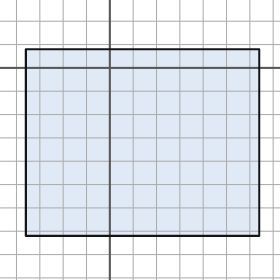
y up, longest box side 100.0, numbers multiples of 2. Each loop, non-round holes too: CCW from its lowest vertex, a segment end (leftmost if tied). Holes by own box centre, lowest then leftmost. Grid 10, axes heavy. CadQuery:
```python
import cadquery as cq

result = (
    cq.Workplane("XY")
    .moveTo(-36.0, -72.0)
    .lineTo(64.0, -72.0)
    .lineTo(64.0, 8.0)
    .lineTo(-36.0, 8.0)
    .close()
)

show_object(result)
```